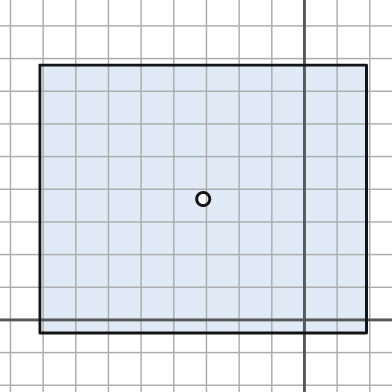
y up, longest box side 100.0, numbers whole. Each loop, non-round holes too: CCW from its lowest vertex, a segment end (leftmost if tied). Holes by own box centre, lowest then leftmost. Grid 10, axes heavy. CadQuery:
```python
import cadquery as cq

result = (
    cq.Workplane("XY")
    .moveTo(-81.0, -4.0)
    .lineTo(19.0, -4.0)
    .lineTo(19.0, 78.0)
    .lineTo(-81.0, 78.0)
    .close()
    .moveTo(-31.0, 37.0)
    .circle(2.0)
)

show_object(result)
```